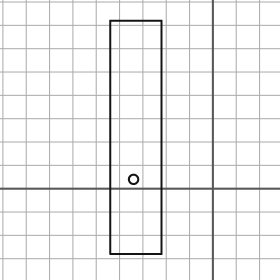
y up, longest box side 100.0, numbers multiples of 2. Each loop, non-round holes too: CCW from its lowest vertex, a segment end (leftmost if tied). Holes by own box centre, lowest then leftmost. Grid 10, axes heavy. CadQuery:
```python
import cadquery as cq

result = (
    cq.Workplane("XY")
    .moveTo(-44.0, -28.0)
    .lineTo(-22.0, -28.0)
    .lineTo(-22.0, 72.0)
    .lineTo(-44.0, 72.0)
    .close()
    .moveTo(-34.0, 4.0)
    .circle(2.0)
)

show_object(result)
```